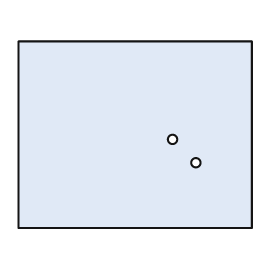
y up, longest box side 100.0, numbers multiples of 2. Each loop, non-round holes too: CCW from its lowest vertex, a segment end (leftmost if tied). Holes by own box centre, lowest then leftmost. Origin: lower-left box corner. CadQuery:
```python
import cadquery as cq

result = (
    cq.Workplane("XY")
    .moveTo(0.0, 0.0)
    .lineTo(100.0, 0.0)
    .lineTo(100.0, 80.0)
    .lineTo(0.0, 80.0)
    .close()
    .moveTo(76.0, 28.0)
    .circle(2.0)
    .moveTo(66.0, 38.0)
    .circle(2.0)
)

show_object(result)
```